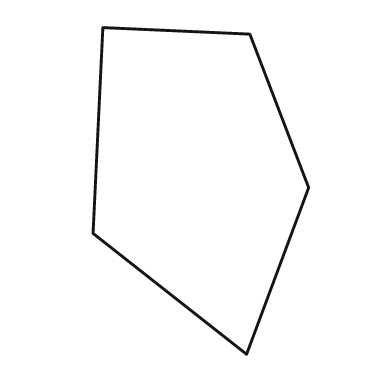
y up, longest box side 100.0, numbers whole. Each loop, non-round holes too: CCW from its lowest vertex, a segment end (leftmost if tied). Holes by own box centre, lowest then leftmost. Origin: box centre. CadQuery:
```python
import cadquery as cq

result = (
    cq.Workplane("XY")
    .moveTo(14.0, -50.0)
    .lineTo(33.0, 1.0)
    .lineTo(15.0, 48.0)
    .lineTo(-30.0, 50.0)
    .lineTo(-33.0, -13.0)
    .close()
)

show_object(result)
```